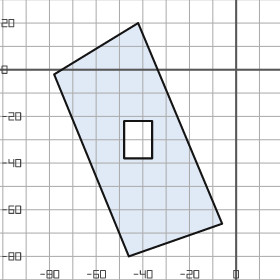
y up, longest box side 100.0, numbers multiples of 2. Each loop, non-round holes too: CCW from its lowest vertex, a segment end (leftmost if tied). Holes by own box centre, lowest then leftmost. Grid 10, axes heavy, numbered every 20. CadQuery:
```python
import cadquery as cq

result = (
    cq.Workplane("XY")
    .moveTo(-46.0, -80.0)
    .lineTo(-6.0, -66.0)
    .lineTo(-42.0, 20.0)
    .lineTo(-78.0, -2.0)
    .close()
    .moveTo(-48.0, -38.0)
    .lineTo(-36.0, -38.0)
    .lineTo(-36.0, -22.0)
    .lineTo(-48.0, -22.0)
    .close()
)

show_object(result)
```